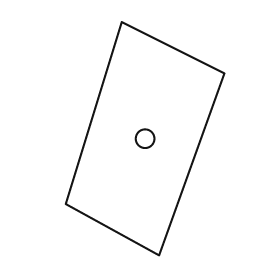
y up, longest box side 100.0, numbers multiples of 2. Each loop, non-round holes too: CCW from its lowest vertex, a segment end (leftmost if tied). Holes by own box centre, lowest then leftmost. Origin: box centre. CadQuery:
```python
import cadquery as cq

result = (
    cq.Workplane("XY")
    .moveTo(6.0, -50.0)
    .lineTo(34.0, 28.0)
    .lineTo(-10.0, 50.0)
    .lineTo(-34.0, -28.0)
    .close()
    .moveTo(0.0, 0.0)
    .circle(4.0)
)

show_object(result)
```